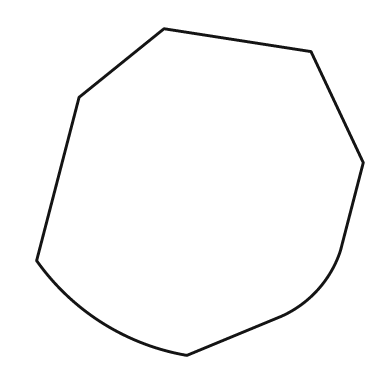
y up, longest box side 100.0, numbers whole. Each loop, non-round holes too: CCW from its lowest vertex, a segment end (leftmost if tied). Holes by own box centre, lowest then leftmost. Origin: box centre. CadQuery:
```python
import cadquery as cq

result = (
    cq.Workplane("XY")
    .moveTo(-4.0, -50.0)
    .lineTo(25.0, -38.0)
    .threePointArc((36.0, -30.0), (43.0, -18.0))
    .lineTo(50.0, 9.0)
    .lineTo(34.0, 43.0)
    .lineTo(-11.0, 50.0)
    .lineTo(-37.0, 29.0)
    .lineTo(-50.0, -21.0)
    .threePointArc((-30.0, -40.0), (-4.0, -50.0))
    .close()
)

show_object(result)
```